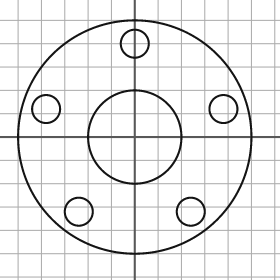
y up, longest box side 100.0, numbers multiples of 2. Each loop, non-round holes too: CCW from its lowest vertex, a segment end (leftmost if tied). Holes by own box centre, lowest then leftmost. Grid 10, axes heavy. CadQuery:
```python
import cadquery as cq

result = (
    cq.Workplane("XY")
    .moveTo(0.0, 0.0)
    .circle(50.0)
    .moveTo(-24.0, -32.0)
    .circle(6.0)
    .moveTo(24.0, -32.0)
    .circle(6.0)
    .moveTo(0.0, 0.0)
    .circle(20.0)
    .moveTo(-38.0, 12.0)
    .circle(6.0)
    .moveTo(38.0, 12.0)
    .circle(6.0)
    .moveTo(0.0, 40.0)
    .circle(6.0)
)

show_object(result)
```